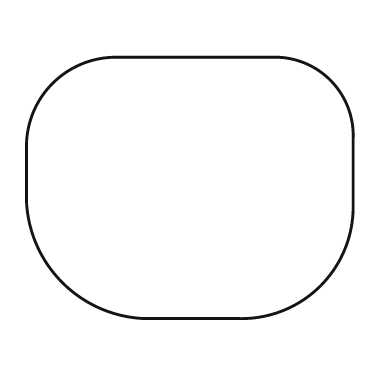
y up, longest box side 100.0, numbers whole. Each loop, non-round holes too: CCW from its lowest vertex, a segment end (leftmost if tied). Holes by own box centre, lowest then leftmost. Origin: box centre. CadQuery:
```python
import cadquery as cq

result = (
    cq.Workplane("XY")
    .moveTo(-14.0, -40.0)
    .lineTo(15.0, -40.0)
    .threePointArc((40.0, -30.0), (50.0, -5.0))
    .lineTo(50.0, 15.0)
    .threePointArc((43.0, 33.0), (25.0, 40.0))
    .lineTo(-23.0, 40.0)
    .threePointArc((-42.0, 32.0), (-50.0, 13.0))
    .lineTo(-50.0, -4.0)
    .threePointArc((-39.0, -29.0), (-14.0, -40.0))
    .close()
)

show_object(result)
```